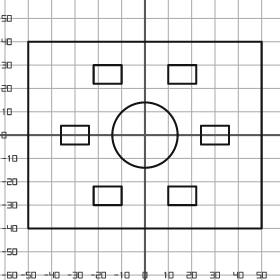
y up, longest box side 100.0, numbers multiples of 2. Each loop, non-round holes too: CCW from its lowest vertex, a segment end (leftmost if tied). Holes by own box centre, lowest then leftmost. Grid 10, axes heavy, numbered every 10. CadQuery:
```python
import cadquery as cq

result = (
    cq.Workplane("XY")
    .moveTo(-50.0, -40.0)
    .lineTo(50.0, -40.0)
    .lineTo(50.0, 40.0)
    .lineTo(-50.0, 40.0)
    .close()
    .moveTo(-22.0, -30.0)
    .lineTo(-10.0, -30.0)
    .lineTo(-10.0, -22.0)
    .lineTo(-22.0, -22.0)
    .close()
    .moveTo(10.0, -30.0)
    .lineTo(22.0, -30.0)
    .lineTo(22.0, -22.0)
    .lineTo(10.0, -22.0)
    .close()
    .moveTo(-36.0, -4.0)
    .lineTo(-24.0, -4.0)
    .lineTo(-24.0, 4.0)
    .lineTo(-36.0, 4.0)
    .close()
    .moveTo(0.0, 0.0)
    .circle(14.0)
    .moveTo(24.0, -4.0)
    .lineTo(36.0, -4.0)
    .lineTo(36.0, 4.0)
    .lineTo(24.0, 4.0)
    .close()
    .moveTo(-22.0, 22.0)
    .lineTo(-10.0, 22.0)
    .lineTo(-10.0, 30.0)
    .lineTo(-22.0, 30.0)
    .close()
    .moveTo(10.0, 22.0)
    .lineTo(22.0, 22.0)
    .lineTo(22.0, 30.0)
    .lineTo(10.0, 30.0)
    .close()
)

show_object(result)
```